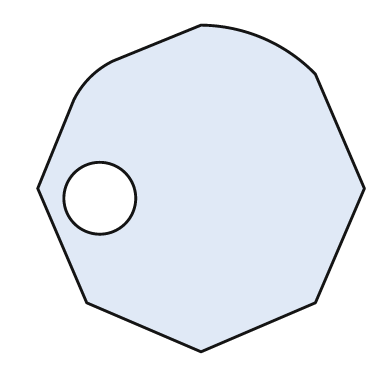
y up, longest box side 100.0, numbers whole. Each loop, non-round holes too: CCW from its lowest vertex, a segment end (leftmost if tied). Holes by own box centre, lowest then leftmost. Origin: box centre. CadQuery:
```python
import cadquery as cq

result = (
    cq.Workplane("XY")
    .moveTo(0.0, -50.0)
    .lineTo(35.0, -35.0)
    .lineTo(50.0, 0.0)
    .lineTo(35.0, 35.0)
    .threePointArc((19.0, 46.0), (0.0, 50.0))
    .lineTo(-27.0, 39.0)
    .threePointArc((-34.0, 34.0), (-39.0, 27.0))
    .lineTo(-50.0, 0.0)
    .lineTo(-35.0, -35.0)
    .close()
    .moveTo(-31.0, -3.0)
    .circle(11.0)
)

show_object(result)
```